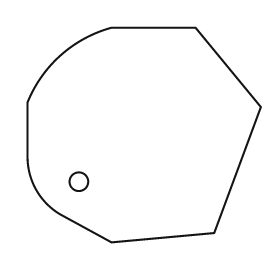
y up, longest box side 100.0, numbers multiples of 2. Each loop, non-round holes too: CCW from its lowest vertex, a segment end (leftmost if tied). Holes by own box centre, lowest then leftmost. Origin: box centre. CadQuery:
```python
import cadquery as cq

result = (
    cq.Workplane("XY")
    .moveTo(-14.0, -46.0)
    .lineTo(30.0, -42.0)
    .lineTo(50.0, 12.0)
    .lineTo(22.0, 46.0)
    .lineTo(-14.0, 46.0)
    .threePointArc((-36.0, 34.0), (-50.0, 14.0))
    .lineTo(-50.0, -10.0)
    .threePointArc((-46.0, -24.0), (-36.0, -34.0))
    .close()
    .moveTo(-28.0, -20.0)
    .circle(4.0)
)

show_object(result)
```